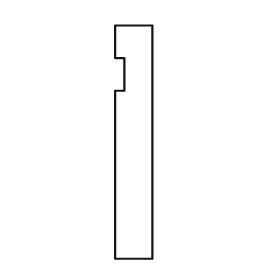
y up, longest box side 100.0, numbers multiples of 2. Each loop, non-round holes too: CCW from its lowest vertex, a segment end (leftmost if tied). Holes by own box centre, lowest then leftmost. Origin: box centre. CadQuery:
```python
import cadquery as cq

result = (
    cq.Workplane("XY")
    .moveTo(-8.0, -50.0)
    .lineTo(8.0, -50.0)
    .lineTo(8.0, 50.0)
    .lineTo(-8.0, 50.0)
    .lineTo(-8.0, 36.0)
    .lineTo(-4.0, 36.0)
    .lineTo(-4.0, 22.0)
    .lineTo(-8.0, 22.0)
    .close()
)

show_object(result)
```